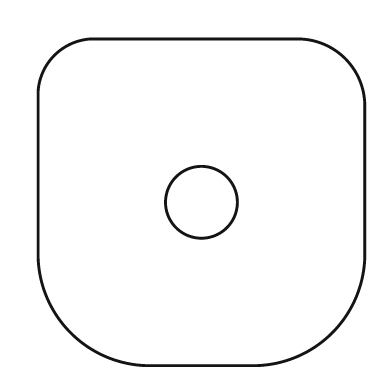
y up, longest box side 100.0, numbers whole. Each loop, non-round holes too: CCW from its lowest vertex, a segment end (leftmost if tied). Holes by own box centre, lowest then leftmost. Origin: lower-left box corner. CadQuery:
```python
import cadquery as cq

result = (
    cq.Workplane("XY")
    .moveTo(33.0, 0.0)
    .lineTo(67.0, 0.0)
    .threePointArc((90.0, 10.0), (100.0, 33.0))
    .lineTo(100.0, 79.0)
    .threePointArc((94.0, 94.0), (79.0, 100.0))
    .lineTo(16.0, 100.0)
    .threePointArc((5.0, 95.0), (0.0, 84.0))
    .lineTo(0.0, 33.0)
    .threePointArc((10.0, 10.0), (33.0, 0.0))
    .close()
    .moveTo(50.0, 50.0)
    .circle(11.0)
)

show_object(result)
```